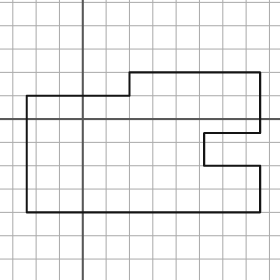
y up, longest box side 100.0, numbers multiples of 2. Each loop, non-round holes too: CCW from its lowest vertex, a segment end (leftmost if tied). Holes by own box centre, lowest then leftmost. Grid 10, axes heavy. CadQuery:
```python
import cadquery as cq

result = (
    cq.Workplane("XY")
    .moveTo(-24.0, -40.0)
    .lineTo(76.0, -40.0)
    .lineTo(76.0, -20.0)
    .lineTo(52.0, -20.0)
    .lineTo(52.0, -6.0)
    .lineTo(76.0, -6.0)
    .lineTo(76.0, 20.0)
    .lineTo(20.0, 20.0)
    .lineTo(20.0, 10.0)
    .lineTo(-24.0, 10.0)
    .close()
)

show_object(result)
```